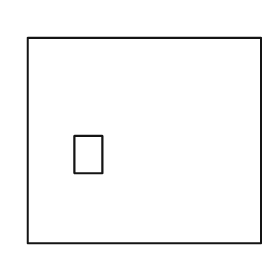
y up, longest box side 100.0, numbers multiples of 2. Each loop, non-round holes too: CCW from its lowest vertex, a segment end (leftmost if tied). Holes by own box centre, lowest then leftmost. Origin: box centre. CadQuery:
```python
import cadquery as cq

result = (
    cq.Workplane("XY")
    .moveTo(-50.0, -44.0)
    .lineTo(50.0, -44.0)
    .lineTo(50.0, 44.0)
    .lineTo(-50.0, 44.0)
    .close()
    .moveTo(-30.0, -14.0)
    .lineTo(-18.0, -14.0)
    .lineTo(-18.0, 2.0)
    .lineTo(-30.0, 2.0)
    .close()
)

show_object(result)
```